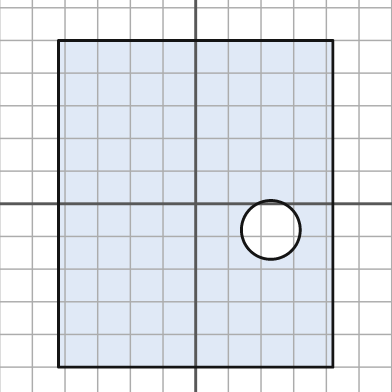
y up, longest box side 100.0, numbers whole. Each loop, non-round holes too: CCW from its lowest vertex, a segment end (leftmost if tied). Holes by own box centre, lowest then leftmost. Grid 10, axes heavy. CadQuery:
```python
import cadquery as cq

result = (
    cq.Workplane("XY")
    .moveTo(-42.0, -50.0)
    .lineTo(42.0, -50.0)
    .lineTo(42.0, 50.0)
    .lineTo(-42.0, 50.0)
    .close()
    .moveTo(23.0, -8.0)
    .circle(9.0)
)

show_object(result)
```